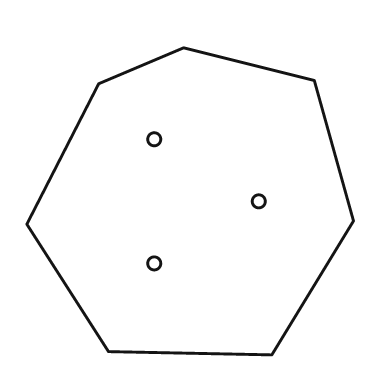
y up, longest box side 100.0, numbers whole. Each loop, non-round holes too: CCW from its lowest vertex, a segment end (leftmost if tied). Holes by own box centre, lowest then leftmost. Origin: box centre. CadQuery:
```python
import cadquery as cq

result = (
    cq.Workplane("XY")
    .moveTo(25.0, -47.0)
    .lineTo(50.0, -6.0)
    .lineTo(38.0, 37.0)
    .lineTo(-2.0, 47.0)
    .lineTo(-28.0, 36.0)
    .lineTo(-50.0, -7.0)
    .lineTo(-25.0, -46.0)
    .close()
    .moveTo(-11.0, -19.0)
    .circle(2.0)
    .moveTo(21.0, 0.0)
    .circle(2.0)
    .moveTo(-11.0, 19.0)
    .circle(2.0)
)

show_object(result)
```